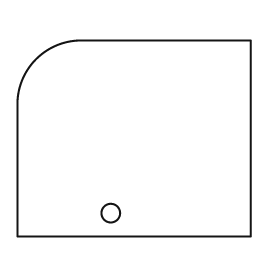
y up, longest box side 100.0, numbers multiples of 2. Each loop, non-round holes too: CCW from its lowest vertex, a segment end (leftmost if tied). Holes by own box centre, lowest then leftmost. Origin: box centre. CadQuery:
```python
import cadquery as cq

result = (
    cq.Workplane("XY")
    .moveTo(-50.0, -42.0)
    .lineTo(50.0, -42.0)
    .lineTo(50.0, 42.0)
    .lineTo(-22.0, 42.0)
    .threePointArc((-42.0, 34.0), (-50.0, 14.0))
    .close()
    .moveTo(-10.0, -32.0)
    .circle(4.0)
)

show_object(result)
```